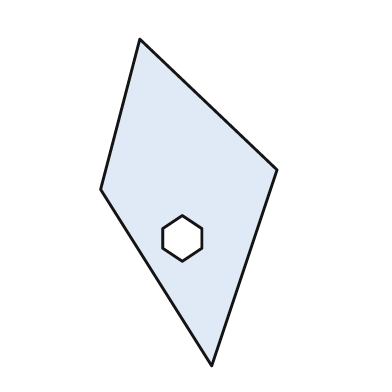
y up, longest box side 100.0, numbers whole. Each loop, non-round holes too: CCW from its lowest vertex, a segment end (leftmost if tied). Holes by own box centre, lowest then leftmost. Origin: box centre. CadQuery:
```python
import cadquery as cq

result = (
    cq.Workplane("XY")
    .moveTo(7.0, -50.0)
    .lineTo(27.0, 10.0)
    .lineTo(-15.0, 50.0)
    .lineTo(-27.0, 4.0)
    .close()
    .moveTo(-2.0, -18.0)
    .lineTo(4.0, -14.0)
    .lineTo(4.0, -8.0)
    .lineTo(-2.0, -4.0)
    .lineTo(-8.0, -8.0)
    .lineTo(-8.0, -14.0)
    .close()
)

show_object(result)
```